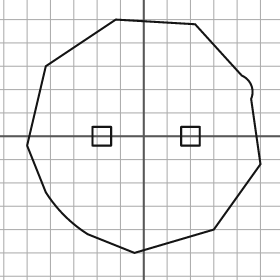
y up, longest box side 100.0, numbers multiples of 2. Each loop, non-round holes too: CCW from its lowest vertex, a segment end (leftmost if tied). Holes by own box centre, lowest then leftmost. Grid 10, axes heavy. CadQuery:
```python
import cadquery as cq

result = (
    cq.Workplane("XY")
    .moveTo(-4.0, -50.0)
    .lineTo(30.0, -40.0)
    .lineTo(50.0, -12.0)
    .lineTo(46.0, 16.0)
    .threePointArc((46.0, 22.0), (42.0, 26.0))
    .lineTo(22.0, 48.0)
    .lineTo(-12.0, 50.0)
    .lineTo(-42.0, 30.0)
    .lineTo(-50.0, -4.0)
    .lineTo(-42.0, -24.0)
    .threePointArc((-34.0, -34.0), (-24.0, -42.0))
    .close()
    .moveTo(-22.0, -4.0)
    .lineTo(-14.0, -4.0)
    .lineTo(-14.0, 4.0)
    .lineTo(-22.0, 4.0)
    .close()
    .moveTo(16.0, -4.0)
    .lineTo(24.0, -4.0)
    .lineTo(24.0, 4.0)
    .lineTo(16.0, 4.0)
    .close()
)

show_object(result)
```